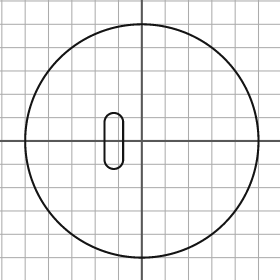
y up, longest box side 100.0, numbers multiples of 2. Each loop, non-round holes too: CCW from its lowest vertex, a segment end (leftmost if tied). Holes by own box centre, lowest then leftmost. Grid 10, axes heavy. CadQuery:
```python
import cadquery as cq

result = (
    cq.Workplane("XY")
    .moveTo(0.0, 0.0)
    .circle(50.0)
    .moveTo(-16.0, -8.0)
    .threePointArc((-12.0, -12.0), (-8.0, -8.0))
    .lineTo(-8.0, 8.0)
    .threePointArc((-12.0, 12.0), (-16.0, 8.0))
    .close()
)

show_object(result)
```